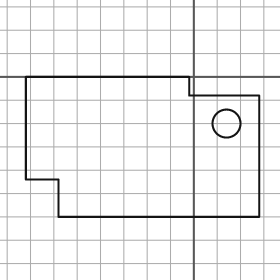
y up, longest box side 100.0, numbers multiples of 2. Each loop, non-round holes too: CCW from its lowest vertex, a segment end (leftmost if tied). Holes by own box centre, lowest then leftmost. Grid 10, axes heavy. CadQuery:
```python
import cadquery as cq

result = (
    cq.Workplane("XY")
    .moveTo(-58.0, -60.0)
    .lineTo(28.0, -60.0)
    .lineTo(28.0, -8.0)
    .lineTo(-2.0, -8.0)
    .lineTo(-2.0, 0.0)
    .lineTo(-72.0, 0.0)
    .lineTo(-72.0, -44.0)
    .lineTo(-58.0, -44.0)
    .close()
    .moveTo(14.0, -20.0)
    .circle(6.0)
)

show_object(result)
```